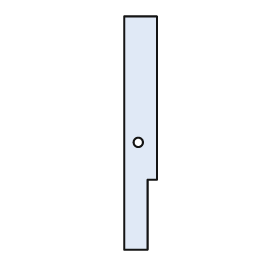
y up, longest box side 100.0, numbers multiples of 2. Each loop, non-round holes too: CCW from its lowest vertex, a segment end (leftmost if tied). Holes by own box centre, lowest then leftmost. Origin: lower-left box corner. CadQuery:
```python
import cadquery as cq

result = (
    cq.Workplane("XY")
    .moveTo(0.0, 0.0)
    .lineTo(10.0, 0.0)
    .lineTo(10.0, 30.0)
    .lineTo(14.0, 30.0)
    .lineTo(14.0, 100.0)
    .lineTo(0.0, 100.0)
    .close()
    .moveTo(6.0, 46.0)
    .circle(2.0)
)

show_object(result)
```